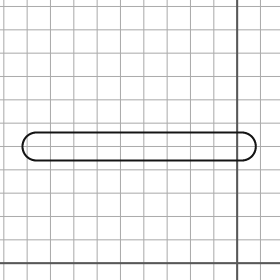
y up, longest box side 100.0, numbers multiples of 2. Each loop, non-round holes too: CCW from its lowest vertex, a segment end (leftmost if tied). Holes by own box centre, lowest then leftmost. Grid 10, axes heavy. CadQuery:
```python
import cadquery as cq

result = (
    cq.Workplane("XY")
    .moveTo(-86.0, 44.0)
    .lineTo(2.0, 44.0)
    .threePointArc((8.0, 50.0), (2.0, 56.0))
    .lineTo(-86.0, 56.0)
    .threePointArc((-92.0, 50.0), (-86.0, 44.0))
    .close()
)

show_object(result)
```